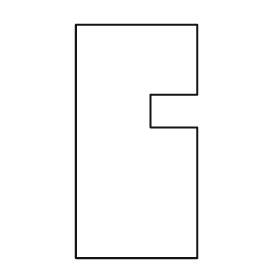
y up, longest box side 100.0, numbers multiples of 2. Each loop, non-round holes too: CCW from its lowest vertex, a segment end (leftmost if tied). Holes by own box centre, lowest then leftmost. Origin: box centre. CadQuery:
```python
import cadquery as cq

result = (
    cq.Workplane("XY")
    .moveTo(-26.0, -50.0)
    .lineTo(26.0, -50.0)
    .lineTo(26.0, 6.0)
    .lineTo(6.0, 6.0)
    .lineTo(6.0, 20.0)
    .lineTo(26.0, 20.0)
    .lineTo(26.0, 50.0)
    .lineTo(-26.0, 50.0)
    .close()
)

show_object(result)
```